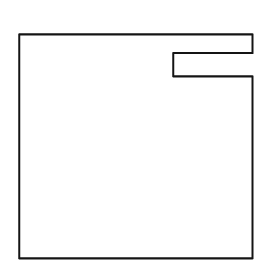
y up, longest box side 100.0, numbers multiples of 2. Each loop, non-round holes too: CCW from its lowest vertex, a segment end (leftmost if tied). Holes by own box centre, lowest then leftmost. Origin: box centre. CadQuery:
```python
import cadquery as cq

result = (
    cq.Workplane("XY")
    .moveTo(-50.0, -48.0)
    .lineTo(50.0, -48.0)
    .lineTo(50.0, 30.0)
    .lineTo(16.0, 30.0)
    .lineTo(16.0, 40.0)
    .lineTo(50.0, 40.0)
    .lineTo(50.0, 48.0)
    .lineTo(-50.0, 48.0)
    .close()
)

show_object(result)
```